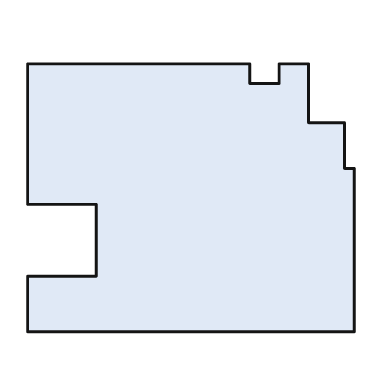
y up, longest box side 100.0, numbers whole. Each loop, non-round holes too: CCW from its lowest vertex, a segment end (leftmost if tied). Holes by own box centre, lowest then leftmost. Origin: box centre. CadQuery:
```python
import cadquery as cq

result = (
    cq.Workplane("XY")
    .moveTo(-50.0, -41.0)
    .lineTo(50.0, -41.0)
    .lineTo(50.0, 9.0)
    .lineTo(47.0, 9.0)
    .lineTo(47.0, 23.0)
    .lineTo(36.0, 23.0)
    .lineTo(36.0, 41.0)
    .lineTo(27.0, 41.0)
    .lineTo(27.0, 35.0)
    .lineTo(18.0, 35.0)
    .lineTo(18.0, 41.0)
    .lineTo(-50.0, 41.0)
    .lineTo(-50.0, -2.0)
    .lineTo(-29.0, -2.0)
    .lineTo(-29.0, -24.0)
    .lineTo(-50.0, -24.0)
    .close()
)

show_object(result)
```